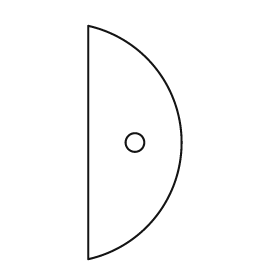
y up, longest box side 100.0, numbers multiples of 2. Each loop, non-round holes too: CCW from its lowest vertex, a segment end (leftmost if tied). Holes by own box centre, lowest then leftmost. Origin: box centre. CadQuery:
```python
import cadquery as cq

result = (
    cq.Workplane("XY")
    .moveTo(-20.0, -50.0)
    .threePointArc((20.0, 0.0), (-20.0, 50.0))
    .close()
    .moveTo(0.0, 0.0)
    .circle(4.0)
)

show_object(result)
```